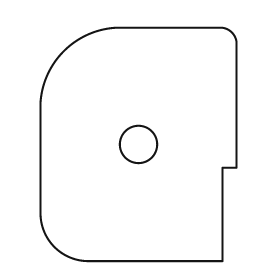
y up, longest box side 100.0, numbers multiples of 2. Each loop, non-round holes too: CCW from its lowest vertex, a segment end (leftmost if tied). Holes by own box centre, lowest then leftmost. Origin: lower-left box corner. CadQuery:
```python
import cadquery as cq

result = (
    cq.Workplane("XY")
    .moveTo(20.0, 0.0)
    .lineTo(78.0, 0.0)
    .lineTo(78.0, 40.0)
    .lineTo(84.0, 40.0)
    .lineTo(84.0, 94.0)
    .threePointArc((82.0, 98.0), (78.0, 100.0))
    .lineTo(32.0, 100.0)
    .threePointArc((10.0, 90.0), (0.0, 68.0))
    .lineTo(0.0, 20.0)
    .threePointArc((6.0, 6.0), (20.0, 0.0))
    .close()
    .moveTo(42.0, 50.0)
    .circle(8.0)
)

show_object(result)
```